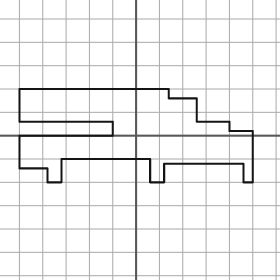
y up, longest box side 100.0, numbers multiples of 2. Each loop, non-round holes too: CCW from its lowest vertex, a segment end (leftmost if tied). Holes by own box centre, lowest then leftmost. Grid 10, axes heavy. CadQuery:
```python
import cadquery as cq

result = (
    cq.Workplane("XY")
    .moveTo(-38.0, -20.0)
    .lineTo(-32.0, -20.0)
    .lineTo(-32.0, -10.0)
    .lineTo(6.0, -10.0)
    .lineTo(6.0, -20.0)
    .lineTo(12.0, -20.0)
    .lineTo(12.0, -12.0)
    .lineTo(46.0, -12.0)
    .lineTo(46.0, -20.0)
    .lineTo(50.0, -20.0)
    .lineTo(50.0, 2.0)
    .lineTo(40.0, 2.0)
    .lineTo(40.0, 6.0)
    .lineTo(26.0, 6.0)
    .lineTo(26.0, 16.0)
    .lineTo(14.0, 16.0)
    .lineTo(14.0, 20.0)
    .lineTo(-50.0, 20.0)
    .lineTo(-50.0, 6.0)
    .lineTo(-10.0, 6.0)
    .lineTo(-10.0, 0.0)
    .lineTo(-50.0, 0.0)
    .lineTo(-50.0, -14.0)
    .lineTo(-38.0, -14.0)
    .close()
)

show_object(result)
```